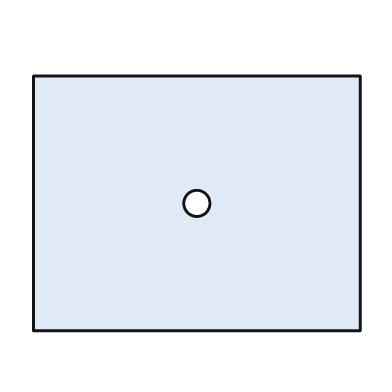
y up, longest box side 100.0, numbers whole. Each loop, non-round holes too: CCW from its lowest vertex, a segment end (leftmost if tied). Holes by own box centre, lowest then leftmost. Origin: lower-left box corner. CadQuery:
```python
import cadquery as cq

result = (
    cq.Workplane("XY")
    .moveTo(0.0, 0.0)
    .lineTo(100.0, 0.0)
    .lineTo(100.0, 78.0)
    .lineTo(0.0, 78.0)
    .close()
    .moveTo(50.0, 39.0)
    .circle(4.0)
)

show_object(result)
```